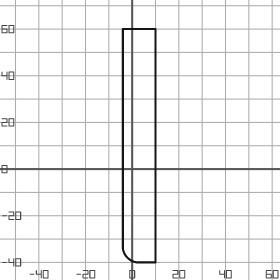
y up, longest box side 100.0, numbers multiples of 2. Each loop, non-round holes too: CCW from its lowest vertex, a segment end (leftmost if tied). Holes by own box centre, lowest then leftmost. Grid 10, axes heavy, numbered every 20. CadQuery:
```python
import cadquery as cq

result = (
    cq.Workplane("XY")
    .moveTo(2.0, -40.0)
    .lineTo(10.0, -40.0)
    .lineTo(10.0, 60.0)
    .lineTo(-4.0, 60.0)
    .lineTo(-4.0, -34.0)
    .threePointArc((-2.0, -38.0), (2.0, -40.0))
    .close()
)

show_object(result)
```